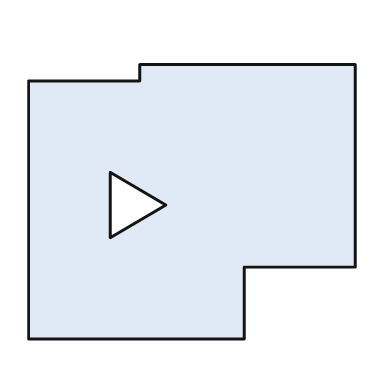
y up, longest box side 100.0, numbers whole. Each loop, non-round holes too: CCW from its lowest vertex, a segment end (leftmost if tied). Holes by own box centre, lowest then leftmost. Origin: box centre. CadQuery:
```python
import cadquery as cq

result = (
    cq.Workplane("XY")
    .moveTo(-50.0, -42.0)
    .lineTo(16.0, -42.0)
    .lineTo(16.0, -20.0)
    .lineTo(50.0, -20.0)
    .lineTo(50.0, 42.0)
    .lineTo(-16.0, 42.0)
    .lineTo(-16.0, 37.0)
    .lineTo(-50.0, 37.0)
    .close()
    .moveTo(-25.0, -11.0)
    .lineTo(-8.0, -1.0)
    .lineTo(-25.0, 9.0)
    .close()
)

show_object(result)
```